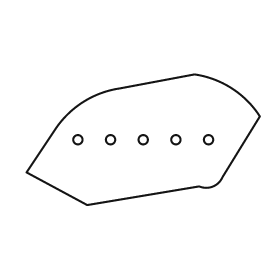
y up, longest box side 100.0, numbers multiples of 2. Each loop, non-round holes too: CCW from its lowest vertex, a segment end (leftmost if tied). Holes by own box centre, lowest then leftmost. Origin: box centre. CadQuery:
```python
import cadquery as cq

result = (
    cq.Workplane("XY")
    .moveTo(-24.0, -28.0)
    .lineTo(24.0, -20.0)
    .threePointArc((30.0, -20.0), (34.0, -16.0))
    .lineTo(50.0, 10.0)
    .threePointArc((38.0, 22.0), (22.0, 28.0))
    .lineTo(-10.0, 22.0)
    .threePointArc((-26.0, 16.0), (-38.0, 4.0))
    .lineTo(-50.0, -14.0)
    .close()
    .moveTo(-28.0, 0.0)
    .circle(2.0)
    .moveTo(-14.0, 0.0)
    .circle(2.0)
    .moveTo(0.0, 0.0)
    .circle(2.0)
    .moveTo(14.0, 0.0)
    .circle(2.0)
    .moveTo(28.0, 0.0)
    .circle(2.0)
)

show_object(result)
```